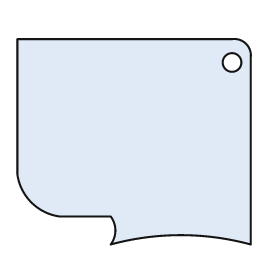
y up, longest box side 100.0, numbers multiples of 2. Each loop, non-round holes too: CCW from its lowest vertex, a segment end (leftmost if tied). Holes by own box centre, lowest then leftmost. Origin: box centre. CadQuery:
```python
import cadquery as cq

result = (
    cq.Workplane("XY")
    .moveTo(-10.0, -44.0)
    .threePointArc((20.0, -40.0), (50.0, -44.0))
    .lineTo(50.0, 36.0)
    .threePointArc((48.0, 42.0), (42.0, 44.0))
    .lineTo(-50.0, 44.0)
    .lineTo(-50.0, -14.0)
    .threePointArc((-44.0, -26.0), (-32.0, -32.0))
    .lineTo(-10.0, -32.0)
    .threePointArc((-8.0, -38.0), (-10.0, -44.0))
    .close()
    .moveTo(42.0, 34.0)
    .circle(4.0)
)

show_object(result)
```